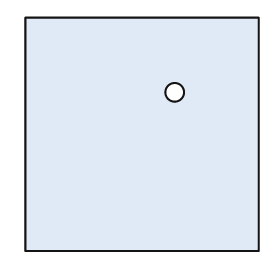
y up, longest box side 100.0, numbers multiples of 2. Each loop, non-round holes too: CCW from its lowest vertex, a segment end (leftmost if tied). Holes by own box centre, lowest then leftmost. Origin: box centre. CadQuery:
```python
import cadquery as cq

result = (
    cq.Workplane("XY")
    .moveTo(-50.0, -50.0)
    .lineTo(50.0, -50.0)
    .lineTo(50.0, 50.0)
    .lineTo(-50.0, 50.0)
    .close()
    .moveTo(14.0, 18.0)
    .circle(4.0)
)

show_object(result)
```